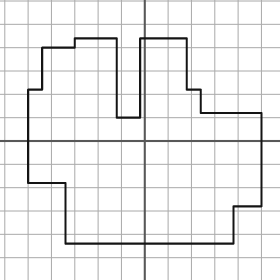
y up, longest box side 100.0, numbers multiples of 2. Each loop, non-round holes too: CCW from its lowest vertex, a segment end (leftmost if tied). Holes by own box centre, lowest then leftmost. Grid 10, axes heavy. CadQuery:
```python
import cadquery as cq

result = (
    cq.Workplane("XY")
    .moveTo(-34.0, -44.0)
    .lineTo(38.0, -44.0)
    .lineTo(38.0, -28.0)
    .lineTo(50.0, -28.0)
    .lineTo(50.0, 12.0)
    .lineTo(24.0, 12.0)
    .lineTo(24.0, 22.0)
    .lineTo(18.0, 22.0)
    .lineTo(18.0, 44.0)
    .lineTo(-2.0, 44.0)
    .lineTo(-2.0, 10.0)
    .lineTo(-12.0, 10.0)
    .lineTo(-12.0, 44.0)
    .lineTo(-30.0, 44.0)
    .lineTo(-30.0, 40.0)
    .lineTo(-44.0, 40.0)
    .lineTo(-44.0, 22.0)
    .lineTo(-50.0, 22.0)
    .lineTo(-50.0, -18.0)
    .lineTo(-34.0, -18.0)
    .close()
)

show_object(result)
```